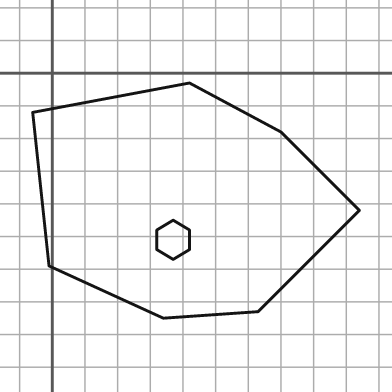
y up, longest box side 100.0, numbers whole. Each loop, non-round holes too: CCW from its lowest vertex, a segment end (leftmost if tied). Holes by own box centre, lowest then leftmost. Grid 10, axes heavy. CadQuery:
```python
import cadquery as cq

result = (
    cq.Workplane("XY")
    .moveTo(34.0, -75.0)
    .lineTo(63.0, -73.0)
    .lineTo(94.0, -42.0)
    .lineTo(70.0, -18.0)
    .lineTo(42.0, -3.0)
    .lineTo(-6.0, -12.0)
    .lineTo(-1.0, -59.0)
    .close()
    .moveTo(37.0, -57.0)
    .lineTo(42.0, -54.0)
    .lineTo(42.0, -48.0)
    .lineTo(37.0, -45.0)
    .lineTo(32.0, -48.0)
    .lineTo(32.0, -54.0)
    .close()
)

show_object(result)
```